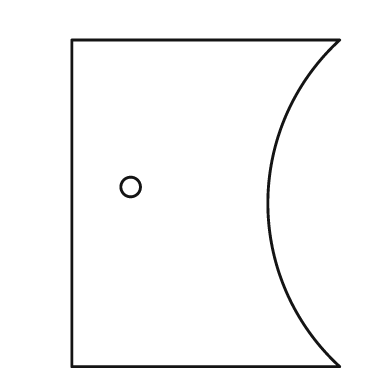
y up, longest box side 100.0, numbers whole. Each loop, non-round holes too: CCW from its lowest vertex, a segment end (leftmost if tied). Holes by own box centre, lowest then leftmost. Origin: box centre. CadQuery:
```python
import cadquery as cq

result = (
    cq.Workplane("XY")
    .moveTo(-41.0, -50.0)
    .lineTo(41.0, -50.0)
    .threePointArc((19.0, 0.0), (41.0, 50.0))
    .lineTo(-41.0, 50.0)
    .close()
    .moveTo(-23.0, 5.0)
    .circle(3.0)
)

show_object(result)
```